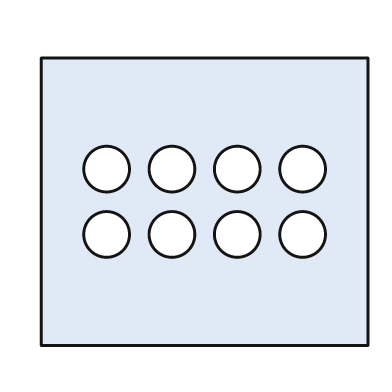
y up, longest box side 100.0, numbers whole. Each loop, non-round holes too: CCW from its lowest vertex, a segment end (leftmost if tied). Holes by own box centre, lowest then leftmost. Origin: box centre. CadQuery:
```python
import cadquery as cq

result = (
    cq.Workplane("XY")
    .moveTo(-50.0, -44.0)
    .lineTo(50.0, -44.0)
    .lineTo(50.0, 44.0)
    .lineTo(-50.0, 44.0)
    .close()
    .moveTo(-30.0, -10.0)
    .circle(7.0)
    .moveTo(-10.0, -10.0)
    .circle(7.0)
    .moveTo(10.0, -10.0)
    .circle(7.0)
    .moveTo(30.0, -10.0)
    .circle(7.0)
    .moveTo(-30.0, 10.0)
    .circle(7.0)
    .moveTo(-10.0, 10.0)
    .circle(7.0)
    .moveTo(10.0, 10.0)
    .circle(7.0)
    .moveTo(30.0, 10.0)
    .circle(7.0)
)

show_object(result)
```